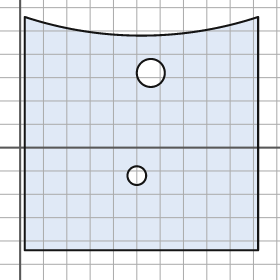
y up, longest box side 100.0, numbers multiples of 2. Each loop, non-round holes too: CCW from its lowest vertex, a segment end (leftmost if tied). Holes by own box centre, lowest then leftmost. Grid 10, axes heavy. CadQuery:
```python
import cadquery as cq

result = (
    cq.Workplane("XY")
    .moveTo(2.0, -44.0)
    .lineTo(102.0, -44.0)
    .lineTo(102.0, 56.0)
    .threePointArc((52.0, 48.0), (2.0, 56.0))
    .close()
    .moveTo(50.0, -12.0)
    .circle(4.0)
    .moveTo(56.0, 32.0)
    .circle(6.0)
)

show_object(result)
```